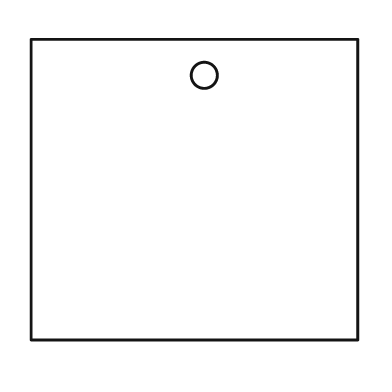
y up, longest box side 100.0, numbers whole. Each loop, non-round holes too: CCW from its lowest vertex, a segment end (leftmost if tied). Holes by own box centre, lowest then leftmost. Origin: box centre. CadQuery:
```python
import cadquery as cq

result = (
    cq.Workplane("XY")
    .moveTo(-50.0, -46.0)
    .lineTo(50.0, -46.0)
    .lineTo(50.0, 46.0)
    .lineTo(-50.0, 46.0)
    .close()
    .moveTo(3.0, 35.0)
    .circle(4.0)
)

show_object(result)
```